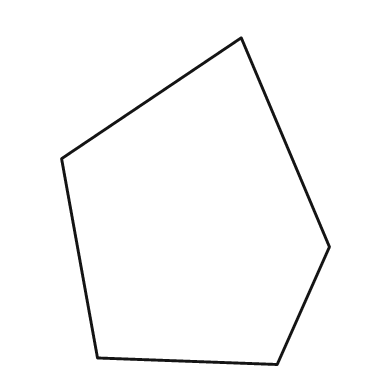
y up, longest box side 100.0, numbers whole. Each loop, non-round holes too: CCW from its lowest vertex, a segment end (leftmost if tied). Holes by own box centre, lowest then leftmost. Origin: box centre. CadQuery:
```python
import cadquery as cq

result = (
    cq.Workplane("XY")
    .moveTo(25.0, -50.0)
    .lineTo(41.0, -14.0)
    .lineTo(14.0, 50.0)
    .lineTo(-41.0, 13.0)
    .lineTo(-30.0, -48.0)
    .close()
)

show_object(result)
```